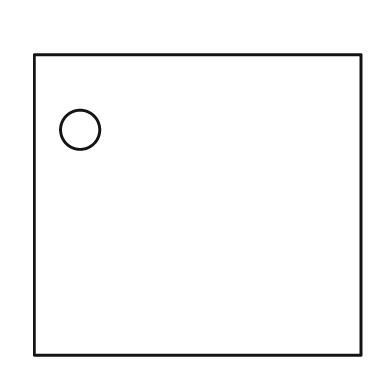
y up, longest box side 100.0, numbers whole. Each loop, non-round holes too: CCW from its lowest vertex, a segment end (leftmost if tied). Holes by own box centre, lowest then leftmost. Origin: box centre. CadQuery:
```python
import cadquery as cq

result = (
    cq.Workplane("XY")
    .moveTo(-50.0, -46.0)
    .lineTo(50.0, -46.0)
    .lineTo(50.0, 46.0)
    .lineTo(-50.0, 46.0)
    .close()
    .moveTo(-36.0, 23.0)
    .circle(6.0)
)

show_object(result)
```